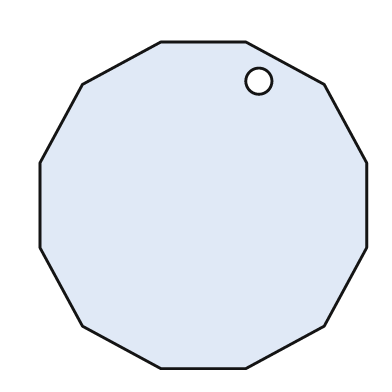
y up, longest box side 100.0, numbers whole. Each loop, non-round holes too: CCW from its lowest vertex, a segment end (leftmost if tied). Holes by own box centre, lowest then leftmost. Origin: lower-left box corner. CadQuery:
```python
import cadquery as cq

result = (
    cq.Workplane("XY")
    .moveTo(37.0, 0.0)
    .lineTo(63.0, 0.0)
    .lineTo(87.0, 13.0)
    .lineTo(100.0, 37.0)
    .lineTo(100.0, 63.0)
    .lineTo(87.0, 87.0)
    .lineTo(63.0, 100.0)
    .lineTo(37.0, 100.0)
    .lineTo(13.0, 87.0)
    .lineTo(0.0, 63.0)
    .lineTo(0.0, 37.0)
    .lineTo(13.0, 13.0)
    .close()
    .moveTo(67.0, 88.0)
    .circle(4.0)
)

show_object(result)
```